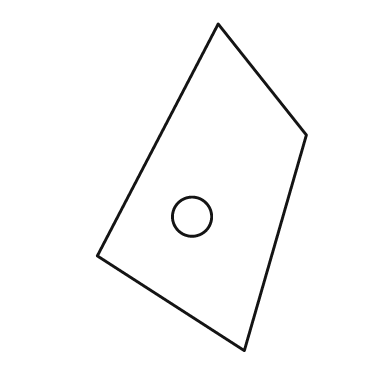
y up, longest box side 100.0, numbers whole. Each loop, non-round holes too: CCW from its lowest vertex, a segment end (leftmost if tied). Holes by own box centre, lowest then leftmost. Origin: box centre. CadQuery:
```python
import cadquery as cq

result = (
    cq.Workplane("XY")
    .moveTo(13.0, -50.0)
    .lineTo(32.0, 16.0)
    .lineTo(5.0, 50.0)
    .lineTo(-32.0, -21.0)
    .close()
    .moveTo(-3.0, -9.0)
    .circle(6.0)
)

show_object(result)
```